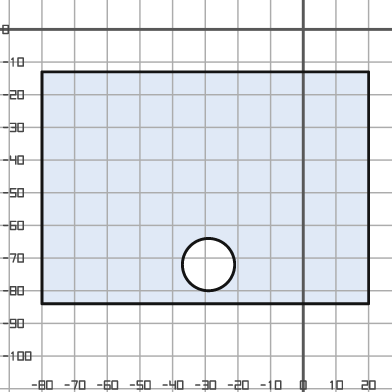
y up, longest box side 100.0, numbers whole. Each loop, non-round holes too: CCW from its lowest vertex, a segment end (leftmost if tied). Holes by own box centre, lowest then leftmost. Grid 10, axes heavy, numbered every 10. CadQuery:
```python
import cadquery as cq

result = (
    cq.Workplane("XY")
    .moveTo(-80.0, -84.0)
    .lineTo(20.0, -84.0)
    .lineTo(20.0, -13.0)
    .lineTo(-80.0, -13.0)
    .close()
    .moveTo(-29.0, -72.0)
    .circle(8.0)
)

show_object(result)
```